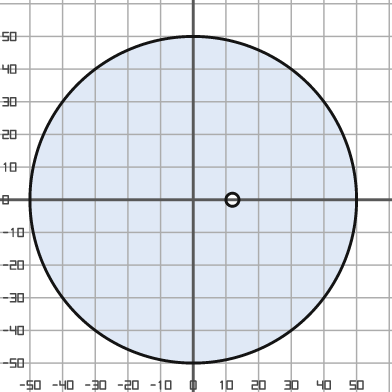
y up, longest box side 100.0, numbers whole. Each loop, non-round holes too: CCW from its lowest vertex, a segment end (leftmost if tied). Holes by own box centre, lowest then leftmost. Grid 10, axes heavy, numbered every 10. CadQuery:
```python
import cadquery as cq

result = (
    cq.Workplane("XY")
    .moveTo(0.0, 0.0)
    .circle(50.0)
    .moveTo(12.0, 0.0)
    .circle(2.0)
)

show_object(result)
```